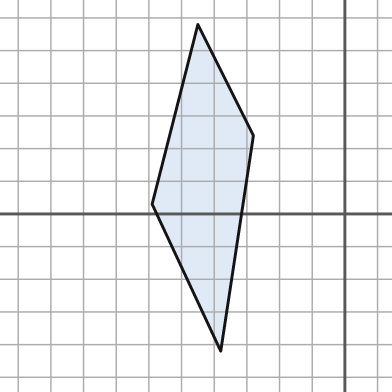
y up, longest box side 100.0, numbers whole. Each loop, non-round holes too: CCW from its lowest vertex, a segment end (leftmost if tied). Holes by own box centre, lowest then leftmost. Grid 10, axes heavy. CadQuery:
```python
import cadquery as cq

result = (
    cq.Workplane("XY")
    .moveTo(-38.0, -42.0)
    .lineTo(-28.0, 24.0)
    .lineTo(-45.0, 58.0)
    .lineTo(-59.0, 3.0)
    .close()
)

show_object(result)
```